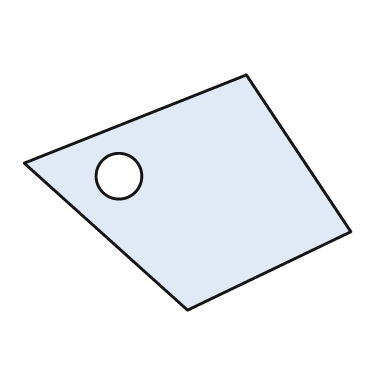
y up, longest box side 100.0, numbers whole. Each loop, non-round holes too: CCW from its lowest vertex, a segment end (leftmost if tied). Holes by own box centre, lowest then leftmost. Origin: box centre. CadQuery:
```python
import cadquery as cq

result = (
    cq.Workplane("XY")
    .moveTo(0.0, -36.0)
    .lineTo(50.0, -12.0)
    .lineTo(18.0, 36.0)
    .lineTo(-50.0, 9.0)
    .close()
    .moveTo(-21.0, 5.0)
    .circle(7.0)
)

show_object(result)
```